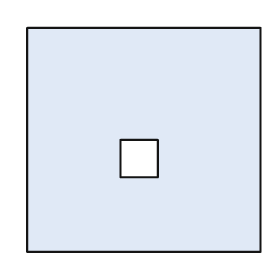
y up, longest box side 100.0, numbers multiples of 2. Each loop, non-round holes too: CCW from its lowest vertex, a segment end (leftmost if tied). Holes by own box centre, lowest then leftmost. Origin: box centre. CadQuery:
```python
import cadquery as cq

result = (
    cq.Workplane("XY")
    .moveTo(-50.0, -48.0)
    .lineTo(50.0, -48.0)
    .lineTo(50.0, 48.0)
    .lineTo(-50.0, 48.0)
    .close()
    .moveTo(-10.0, -16.0)
    .lineTo(6.0, -16.0)
    .lineTo(6.0, 0.0)
    .lineTo(-10.0, 0.0)
    .close()
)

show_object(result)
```